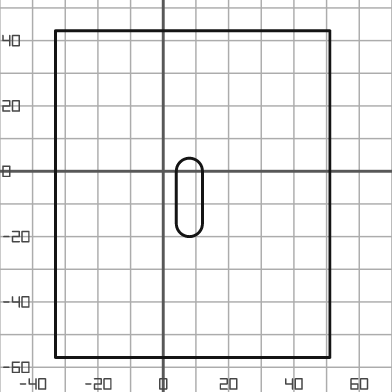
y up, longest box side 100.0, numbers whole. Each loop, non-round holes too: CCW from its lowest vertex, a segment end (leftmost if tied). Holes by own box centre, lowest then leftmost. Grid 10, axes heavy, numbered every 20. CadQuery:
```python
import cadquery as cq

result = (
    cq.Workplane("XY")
    .moveTo(-33.0, -57.0)
    .lineTo(51.0, -57.0)
    .lineTo(51.0, 43.0)
    .lineTo(-33.0, 43.0)
    .close()
    .moveTo(4.0, -16.0)
    .threePointArc((8.0, -20.0), (12.0, -16.0))
    .lineTo(12.0, 0.0)
    .threePointArc((8.0, 4.0), (4.0, 0.0))
    .close()
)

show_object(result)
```